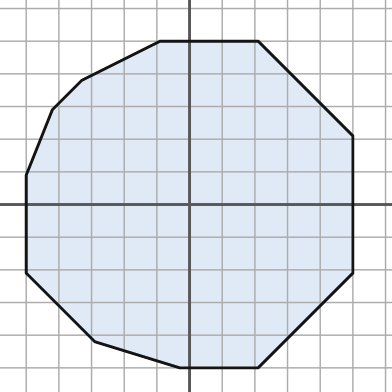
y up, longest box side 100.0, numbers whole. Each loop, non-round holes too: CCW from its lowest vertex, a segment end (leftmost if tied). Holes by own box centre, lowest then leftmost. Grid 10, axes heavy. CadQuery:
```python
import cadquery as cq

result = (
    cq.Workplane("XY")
    .moveTo(-3.0, -50.0)
    .lineTo(21.0, -50.0)
    .lineTo(50.0, -21.0)
    .lineTo(50.0, 21.0)
    .lineTo(21.0, 50.0)
    .lineTo(-9.0, 50.0)
    .lineTo(-33.0, 38.0)
    .lineTo(-42.0, 29.0)
    .lineTo(-50.0, 9.0)
    .lineTo(-50.0, -21.0)
    .lineTo(-29.0, -42.0)
    .close()
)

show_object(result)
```